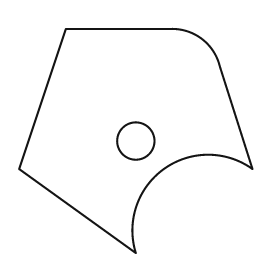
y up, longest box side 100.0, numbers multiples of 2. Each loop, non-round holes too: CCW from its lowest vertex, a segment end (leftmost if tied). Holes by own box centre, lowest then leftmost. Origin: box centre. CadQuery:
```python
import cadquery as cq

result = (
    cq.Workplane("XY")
    .moveTo(0.0, -48.0)
    .threePointArc((12.0, -12.0), (50.0, -12.0))
    .lineTo(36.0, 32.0)
    .threePointArc((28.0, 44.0), (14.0, 48.0))
    .lineTo(-30.0, 48.0)
    .lineTo(-50.0, -12.0)
    .close()
    .moveTo(0.0, 0.0)
    .circle(8.0)
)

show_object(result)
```